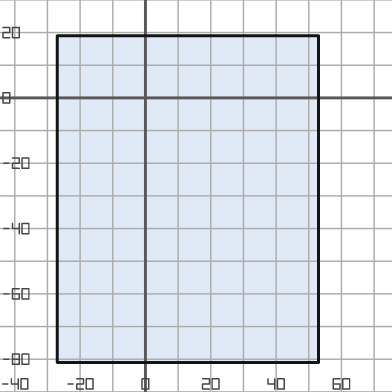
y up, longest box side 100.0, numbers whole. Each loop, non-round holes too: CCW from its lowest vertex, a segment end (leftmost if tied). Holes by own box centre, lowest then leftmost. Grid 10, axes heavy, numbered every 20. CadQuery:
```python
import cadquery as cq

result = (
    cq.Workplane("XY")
    .moveTo(-27.0, -81.0)
    .lineTo(53.0, -81.0)
    .lineTo(53.0, 19.0)
    .lineTo(-27.0, 19.0)
    .close()
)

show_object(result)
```